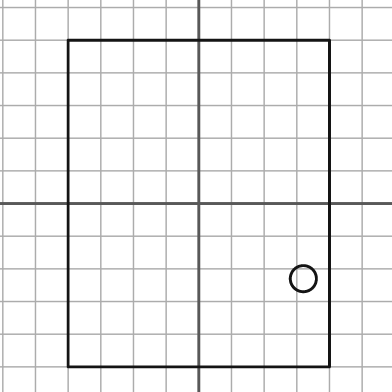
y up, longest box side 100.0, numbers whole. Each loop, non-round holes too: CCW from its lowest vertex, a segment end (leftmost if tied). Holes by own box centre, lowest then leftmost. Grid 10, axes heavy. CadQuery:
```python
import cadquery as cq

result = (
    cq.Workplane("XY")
    .moveTo(-40.0, -50.0)
    .lineTo(40.0, -50.0)
    .lineTo(40.0, 50.0)
    .lineTo(-40.0, 50.0)
    .close()
    .moveTo(32.0, -23.0)
    .circle(4.0)
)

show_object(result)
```